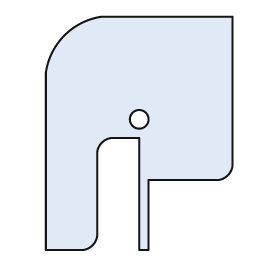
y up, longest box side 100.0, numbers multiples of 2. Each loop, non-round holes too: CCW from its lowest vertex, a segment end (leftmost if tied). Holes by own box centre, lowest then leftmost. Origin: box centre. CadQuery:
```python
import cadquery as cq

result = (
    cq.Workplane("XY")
    .moveTo(-40.0, -50.0)
    .lineTo(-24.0, -50.0)
    .threePointArc((-20.0, -48.0), (-18.0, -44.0))
    .lineTo(-18.0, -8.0)
    .threePointArc((-16.0, -4.0), (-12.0, -2.0))
    .lineTo(0.0, -2.0)
    .lineTo(0.0, -50.0)
    .lineTo(4.0, -50.0)
    .lineTo(4.0, -20.0)
    .lineTo(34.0, -20.0)
    .threePointArc((38.0, -18.0), (40.0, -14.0))
    .lineTo(40.0, 50.0)
    .lineTo(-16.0, 50.0)
    .threePointArc((-32.0, 42.0), (-40.0, 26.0))
    .close()
    .moveTo(0.0, 6.0)
    .circle(4.0)
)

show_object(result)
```